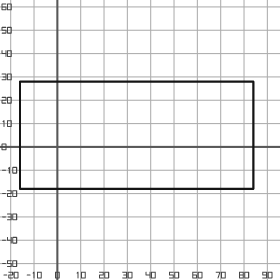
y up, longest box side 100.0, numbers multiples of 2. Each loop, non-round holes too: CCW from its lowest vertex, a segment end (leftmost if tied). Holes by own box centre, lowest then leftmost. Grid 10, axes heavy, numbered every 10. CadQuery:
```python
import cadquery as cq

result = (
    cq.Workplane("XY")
    .moveTo(-16.0, -18.0)
    .lineTo(84.0, -18.0)
    .lineTo(84.0, 28.0)
    .lineTo(-16.0, 28.0)
    .close()
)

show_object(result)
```